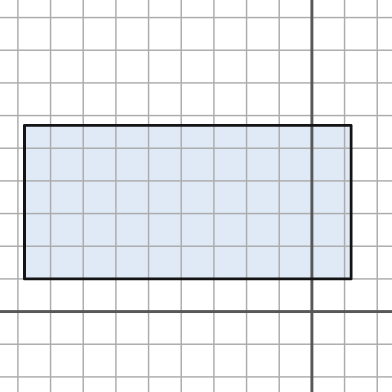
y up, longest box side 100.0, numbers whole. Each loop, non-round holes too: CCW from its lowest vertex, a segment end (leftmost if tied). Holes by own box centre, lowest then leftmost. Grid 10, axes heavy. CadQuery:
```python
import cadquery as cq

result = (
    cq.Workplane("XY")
    .moveTo(-88.0, 10.0)
    .lineTo(12.0, 10.0)
    .lineTo(12.0, 57.0)
    .lineTo(-88.0, 57.0)
    .close()
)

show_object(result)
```